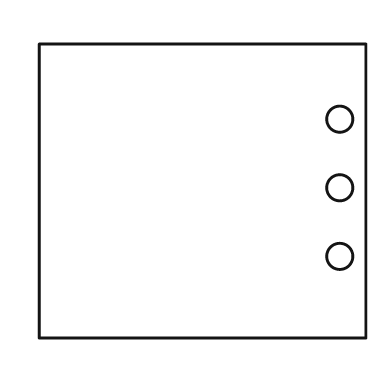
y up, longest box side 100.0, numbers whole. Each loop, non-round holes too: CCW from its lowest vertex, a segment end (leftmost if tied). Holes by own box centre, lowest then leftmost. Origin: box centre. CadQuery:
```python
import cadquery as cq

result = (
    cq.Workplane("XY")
    .moveTo(-50.0, -45.0)
    .lineTo(50.0, -45.0)
    .lineTo(50.0, 45.0)
    .lineTo(-50.0, 45.0)
    .close()
    .moveTo(42.0, -20.0)
    .circle(4.0)
    .moveTo(42.0, 1.0)
    .circle(4.0)
    .moveTo(42.0, 22.0)
    .circle(4.0)
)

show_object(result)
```